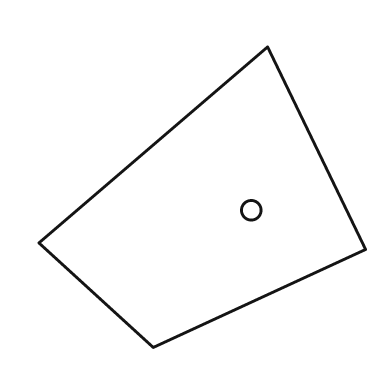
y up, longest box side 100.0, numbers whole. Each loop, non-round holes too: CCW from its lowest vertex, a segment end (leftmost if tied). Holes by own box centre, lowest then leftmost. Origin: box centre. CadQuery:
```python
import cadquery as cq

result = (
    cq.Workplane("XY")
    .moveTo(-15.0, -46.0)
    .lineTo(50.0, -16.0)
    .lineTo(20.0, 46.0)
    .lineTo(-50.0, -14.0)
    .close()
    .moveTo(15.0, -4.0)
    .circle(3.0)
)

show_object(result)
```